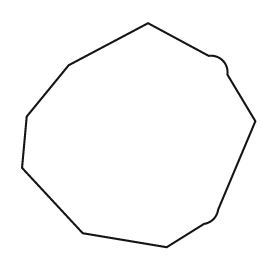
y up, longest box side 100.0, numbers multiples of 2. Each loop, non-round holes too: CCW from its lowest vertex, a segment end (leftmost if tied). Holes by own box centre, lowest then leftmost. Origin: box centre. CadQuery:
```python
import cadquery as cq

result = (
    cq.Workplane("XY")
    .moveTo(12.0, -48.0)
    .lineTo(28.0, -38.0)
    .threePointArc((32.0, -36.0), (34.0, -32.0))
    .lineTo(50.0, 6.0)
    .lineTo(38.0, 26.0)
    .threePointArc((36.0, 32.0), (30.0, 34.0))
    .lineTo(4.0, 48.0)
    .lineTo(-30.0, 30.0)
    .lineTo(-48.0, 8.0)
    .lineTo(-50.0, -14.0)
    .lineTo(-24.0, -42.0)
    .close()
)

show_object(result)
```